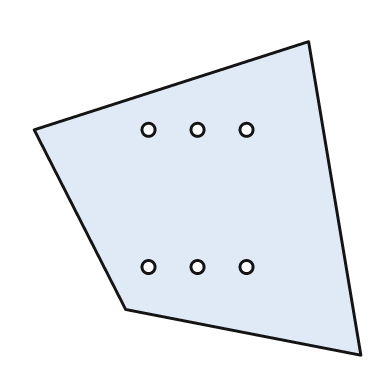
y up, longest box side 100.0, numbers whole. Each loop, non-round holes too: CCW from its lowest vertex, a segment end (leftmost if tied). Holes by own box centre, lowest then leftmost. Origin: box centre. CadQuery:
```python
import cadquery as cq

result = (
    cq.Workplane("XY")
    .moveTo(50.0, -48.0)
    .lineTo(34.0, 48.0)
    .lineTo(-50.0, 21.0)
    .lineTo(-22.0, -34.0)
    .close()
    .moveTo(-15.0, -21.0)
    .circle(2.0)
    .moveTo(0.0, -21.0)
    .circle(2.0)
    .moveTo(15.0, -21.0)
    .circle(2.0)
    .moveTo(-15.0, 21.0)
    .circle(2.0)
    .moveTo(0.0, 21.0)
    .circle(2.0)
    .moveTo(15.0, 21.0)
    .circle(2.0)
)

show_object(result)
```